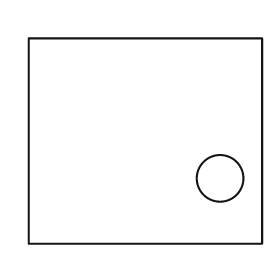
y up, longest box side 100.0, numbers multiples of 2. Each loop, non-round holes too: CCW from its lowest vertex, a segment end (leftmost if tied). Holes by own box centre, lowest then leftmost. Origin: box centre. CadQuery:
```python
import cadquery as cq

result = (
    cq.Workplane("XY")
    .moveTo(-50.0, -44.0)
    .lineTo(50.0, -44.0)
    .lineTo(50.0, 44.0)
    .lineTo(-50.0, 44.0)
    .close()
    .moveTo(32.0, -16.0)
    .circle(10.0)
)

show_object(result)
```